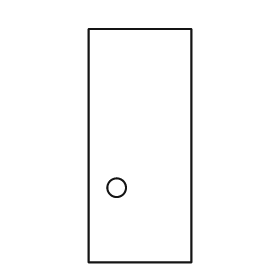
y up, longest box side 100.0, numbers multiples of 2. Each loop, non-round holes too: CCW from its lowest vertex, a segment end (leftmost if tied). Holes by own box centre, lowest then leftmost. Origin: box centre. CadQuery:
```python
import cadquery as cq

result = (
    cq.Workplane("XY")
    .moveTo(-22.0, -50.0)
    .lineTo(22.0, -50.0)
    .lineTo(22.0, 50.0)
    .lineTo(-22.0, 50.0)
    .close()
    .moveTo(-10.0, -18.0)
    .circle(4.0)
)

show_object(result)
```